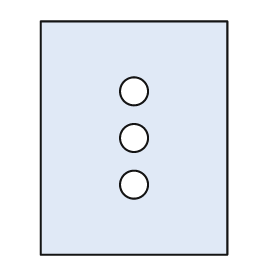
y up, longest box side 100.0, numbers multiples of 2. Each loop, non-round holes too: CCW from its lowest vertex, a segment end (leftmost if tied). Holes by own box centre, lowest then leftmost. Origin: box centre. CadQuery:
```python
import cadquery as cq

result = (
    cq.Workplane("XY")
    .moveTo(-40.0, -50.0)
    .lineTo(40.0, -50.0)
    .lineTo(40.0, 50.0)
    .lineTo(-40.0, 50.0)
    .close()
    .moveTo(0.0, -20.0)
    .circle(6.0)
    .moveTo(0.0, 0.0)
    .circle(6.0)
    .moveTo(0.0, 20.0)
    .circle(6.0)
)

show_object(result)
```